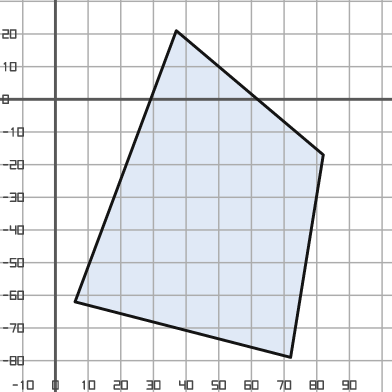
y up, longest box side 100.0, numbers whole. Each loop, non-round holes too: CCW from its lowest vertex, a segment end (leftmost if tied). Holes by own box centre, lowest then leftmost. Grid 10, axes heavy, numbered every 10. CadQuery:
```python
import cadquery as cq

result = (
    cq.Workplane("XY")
    .moveTo(72.0, -79.0)
    .lineTo(82.0, -17.0)
    .lineTo(37.0, 21.0)
    .lineTo(6.0, -62.0)
    .close()
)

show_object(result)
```